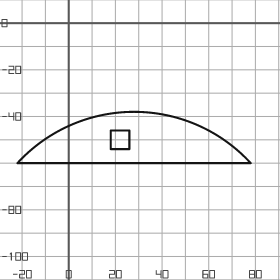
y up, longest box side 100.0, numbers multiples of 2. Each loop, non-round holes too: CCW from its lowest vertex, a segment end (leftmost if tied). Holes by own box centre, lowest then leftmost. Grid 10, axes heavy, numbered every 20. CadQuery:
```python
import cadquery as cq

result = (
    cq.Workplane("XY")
    .moveTo(-22.0, -60.0)
    .lineTo(78.0, -60.0)
    .threePointArc((28.0, -38.0), (-22.0, -60.0))
    .close()
    .moveTo(18.0, -54.0)
    .lineTo(26.0, -54.0)
    .lineTo(26.0, -46.0)
    .lineTo(18.0, -46.0)
    .close()
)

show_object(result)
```